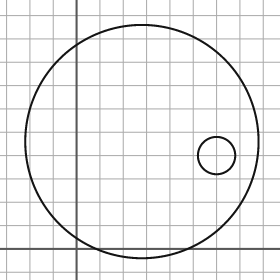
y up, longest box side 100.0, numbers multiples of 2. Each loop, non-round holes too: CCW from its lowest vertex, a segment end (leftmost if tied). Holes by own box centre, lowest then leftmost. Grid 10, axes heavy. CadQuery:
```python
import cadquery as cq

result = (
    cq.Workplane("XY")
    .moveTo(28.0, 46.0)
    .circle(50.0)
    .moveTo(60.0, 40.0)
    .circle(8.0)
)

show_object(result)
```